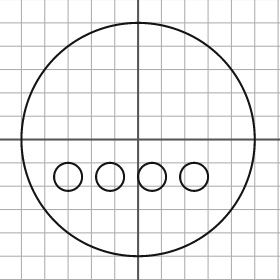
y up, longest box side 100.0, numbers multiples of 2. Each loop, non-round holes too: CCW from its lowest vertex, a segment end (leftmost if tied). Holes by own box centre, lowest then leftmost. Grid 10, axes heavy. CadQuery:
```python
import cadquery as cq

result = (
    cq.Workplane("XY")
    .moveTo(0.0, 0.0)
    .circle(50.0)
    .moveTo(-30.0, -16.0)
    .circle(6.0)
    .moveTo(-12.0, -16.0)
    .circle(6.0)
    .moveTo(6.0, -16.0)
    .circle(6.0)
    .moveTo(24.0, -16.0)
    .circle(6.0)
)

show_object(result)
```